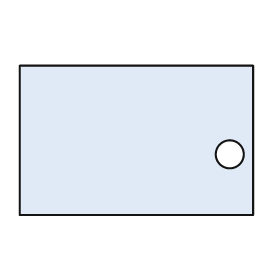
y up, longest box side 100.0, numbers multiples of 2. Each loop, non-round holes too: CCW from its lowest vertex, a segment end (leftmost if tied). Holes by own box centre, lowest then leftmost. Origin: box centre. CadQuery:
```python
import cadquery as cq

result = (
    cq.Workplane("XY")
    .moveTo(-50.0, -32.0)
    .lineTo(50.0, -32.0)
    .lineTo(50.0, 32.0)
    .lineTo(-50.0, 32.0)
    .close()
    .moveTo(40.0, -6.0)
    .circle(6.0)
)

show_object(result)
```